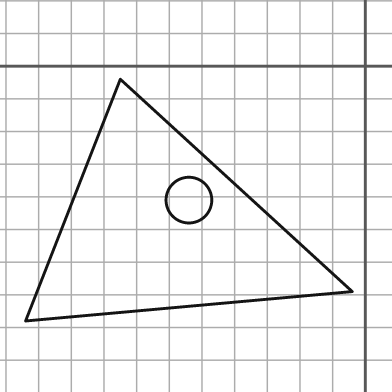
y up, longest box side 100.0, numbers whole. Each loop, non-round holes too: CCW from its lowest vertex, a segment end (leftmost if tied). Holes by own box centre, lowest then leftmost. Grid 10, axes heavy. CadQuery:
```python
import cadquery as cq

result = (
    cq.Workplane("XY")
    .moveTo(-104.0, -78.0)
    .lineTo(-4.0, -69.0)
    .lineTo(-75.0, -4.0)
    .close()
    .moveTo(-54.0, -41.0)
    .circle(7.0)
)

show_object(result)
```